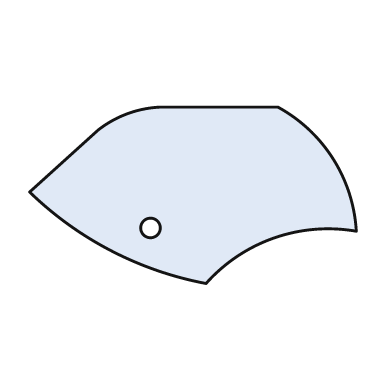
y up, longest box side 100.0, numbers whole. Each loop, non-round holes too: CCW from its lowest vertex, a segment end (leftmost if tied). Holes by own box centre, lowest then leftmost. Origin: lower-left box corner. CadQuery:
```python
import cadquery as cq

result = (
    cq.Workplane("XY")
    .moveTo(54.0, 0.0)
    .threePointArc((75.0, 14.0), (100.0, 16.0))
    .threePointArc((93.0, 38.0), (76.0, 54.0))
    .lineTo(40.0, 54.0)
    .threePointArc((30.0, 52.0), (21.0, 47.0))
    .lineTo(0.0, 28.0)
    .threePointArc((25.0, 10.0), (54.0, 0.0))
    .close()
    .moveTo(37.0, 17.0)
    .circle(3.0)
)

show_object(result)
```